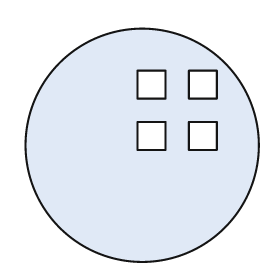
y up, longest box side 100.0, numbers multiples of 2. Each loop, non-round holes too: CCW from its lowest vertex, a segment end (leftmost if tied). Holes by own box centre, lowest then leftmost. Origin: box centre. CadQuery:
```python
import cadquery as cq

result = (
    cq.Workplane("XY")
    .moveTo(0.0, 0.0)
    .circle(50.0)
    .moveTo(-2.0, -2.0)
    .lineTo(10.0, -2.0)
    .lineTo(10.0, 10.0)
    .lineTo(-2.0, 10.0)
    .close()
    .moveTo(20.0, -2.0)
    .lineTo(32.0, -2.0)
    .lineTo(32.0, 10.0)
    .lineTo(20.0, 10.0)
    .close()
    .moveTo(-2.0, 20.0)
    .lineTo(10.0, 20.0)
    .lineTo(10.0, 32.0)
    .lineTo(-2.0, 32.0)
    .close()
    .moveTo(20.0, 20.0)
    .lineTo(32.0, 20.0)
    .lineTo(32.0, 32.0)
    .lineTo(20.0, 32.0)
    .close()
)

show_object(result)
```